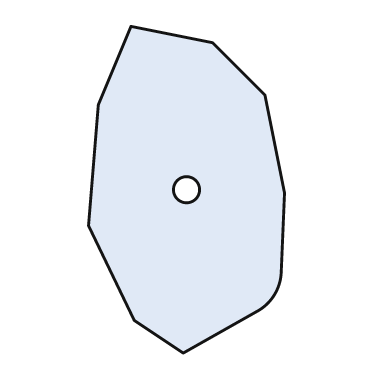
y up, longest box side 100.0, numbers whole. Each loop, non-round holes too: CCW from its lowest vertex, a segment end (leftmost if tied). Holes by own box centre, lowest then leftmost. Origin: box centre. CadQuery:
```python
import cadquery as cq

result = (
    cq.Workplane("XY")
    .moveTo(-1.0, -50.0)
    .lineTo(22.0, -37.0)
    .threePointArc((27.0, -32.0), (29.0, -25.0))
    .lineTo(30.0, -1.0)
    .lineTo(24.0, 29.0)
    .lineTo(8.0, 45.0)
    .lineTo(-17.0, 50.0)
    .lineTo(-27.0, 26.0)
    .lineTo(-30.0, -11.0)
    .lineTo(-16.0, -40.0)
    .close()
    .moveTo(0.0, 0.0)
    .circle(4.0)
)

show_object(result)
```